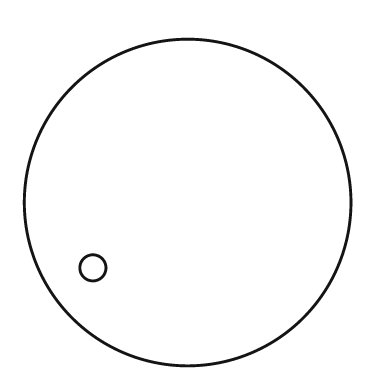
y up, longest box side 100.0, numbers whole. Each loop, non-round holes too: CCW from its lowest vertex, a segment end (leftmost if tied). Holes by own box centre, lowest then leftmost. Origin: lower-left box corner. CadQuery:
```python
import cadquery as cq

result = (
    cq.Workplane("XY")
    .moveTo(50.0, 50.0)
    .circle(50.0)
    .moveTo(21.0, 30.0)
    .circle(4.0)
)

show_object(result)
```